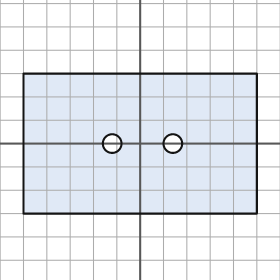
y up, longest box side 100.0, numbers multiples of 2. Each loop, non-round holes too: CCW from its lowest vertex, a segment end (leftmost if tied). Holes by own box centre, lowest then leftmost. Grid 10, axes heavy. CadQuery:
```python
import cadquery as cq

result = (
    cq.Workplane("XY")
    .moveTo(-50.0, -30.0)
    .lineTo(50.0, -30.0)
    .lineTo(50.0, 30.0)
    .lineTo(-50.0, 30.0)
    .close()
    .moveTo(-12.0, 0.0)
    .circle(4.0)
    .moveTo(14.0, 0.0)
    .circle(4.0)
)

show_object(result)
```